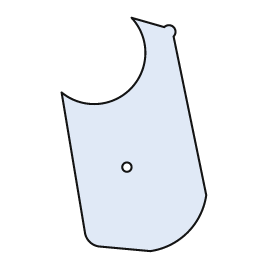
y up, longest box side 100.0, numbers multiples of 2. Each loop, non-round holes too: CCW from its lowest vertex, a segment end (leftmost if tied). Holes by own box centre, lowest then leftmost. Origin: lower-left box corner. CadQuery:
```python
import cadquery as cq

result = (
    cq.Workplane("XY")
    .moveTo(38.0, 0.0)
    .threePointArc((54.0, 8.0), (62.0, 24.0))
    .lineTo(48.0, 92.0)
    .threePointArc((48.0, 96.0), (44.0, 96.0))
    .lineTo(30.0, 100.0)
    .threePointArc((30.0, 70.0), (0.0, 68.0))
    .lineTo(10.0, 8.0)
    .threePointArc((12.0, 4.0), (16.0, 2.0))
    .close()
    .moveTo(28.0, 36.0)
    .circle(2.0)
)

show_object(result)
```